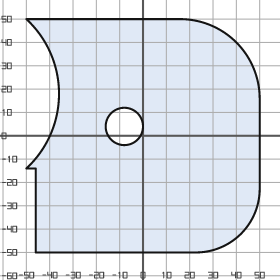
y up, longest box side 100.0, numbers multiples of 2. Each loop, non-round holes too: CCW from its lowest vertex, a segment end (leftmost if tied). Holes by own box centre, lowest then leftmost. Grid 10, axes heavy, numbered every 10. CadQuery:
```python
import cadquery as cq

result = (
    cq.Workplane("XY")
    .moveTo(-46.0, -50.0)
    .lineTo(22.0, -50.0)
    .threePointArc((42.0, -42.0), (50.0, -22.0))
    .lineTo(50.0, 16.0)
    .threePointArc((40.0, 40.0), (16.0, 50.0))
    .lineTo(-50.0, 50.0)
    .threePointArc((-36.0, 18.0), (-50.0, -14.0))
    .lineTo(-46.0, -14.0)
    .close()
    .moveTo(-8.0, 4.0)
    .circle(8.0)
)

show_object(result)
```